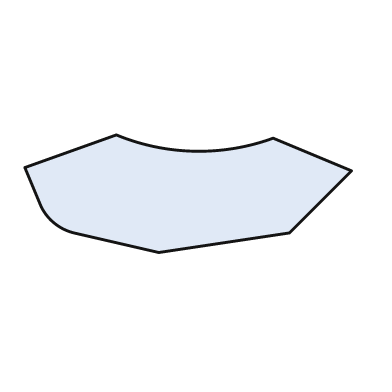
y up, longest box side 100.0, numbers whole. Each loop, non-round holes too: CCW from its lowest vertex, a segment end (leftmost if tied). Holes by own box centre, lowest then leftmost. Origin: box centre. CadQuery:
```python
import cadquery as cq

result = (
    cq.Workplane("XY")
    .moveTo(-9.0, -18.0)
    .lineTo(31.0, -12.0)
    .lineTo(50.0, 7.0)
    .lineTo(26.0, 17.0)
    .threePointArc((2.0, 13.0), (-22.0, 18.0))
    .lineTo(-50.0, 8.0)
    .lineTo(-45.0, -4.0)
    .threePointArc((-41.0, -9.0), (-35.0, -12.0))
    .close()
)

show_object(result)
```